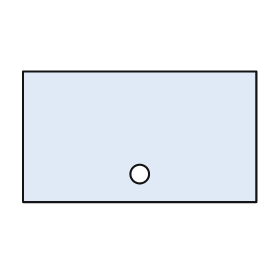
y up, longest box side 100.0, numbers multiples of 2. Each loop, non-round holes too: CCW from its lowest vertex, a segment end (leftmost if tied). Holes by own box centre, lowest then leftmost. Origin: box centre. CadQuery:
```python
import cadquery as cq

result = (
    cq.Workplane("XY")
    .moveTo(-50.0, -28.0)
    .lineTo(50.0, -28.0)
    .lineTo(50.0, 28.0)
    .lineTo(-50.0, 28.0)
    .close()
    .moveTo(0.0, -16.0)
    .circle(4.0)
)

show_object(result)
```